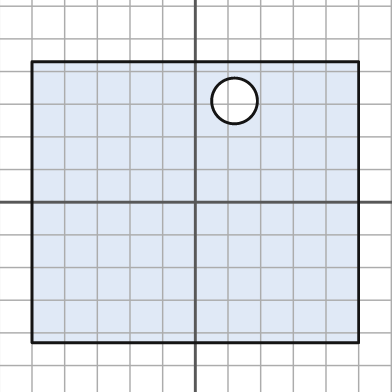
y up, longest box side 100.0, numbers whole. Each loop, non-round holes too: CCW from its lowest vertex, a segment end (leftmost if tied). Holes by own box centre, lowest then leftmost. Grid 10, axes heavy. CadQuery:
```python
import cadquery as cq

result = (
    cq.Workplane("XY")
    .moveTo(-50.0, -43.0)
    .lineTo(50.0, -43.0)
    .lineTo(50.0, 43.0)
    .lineTo(-50.0, 43.0)
    .close()
    .moveTo(12.0, 31.0)
    .circle(7.0)
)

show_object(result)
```